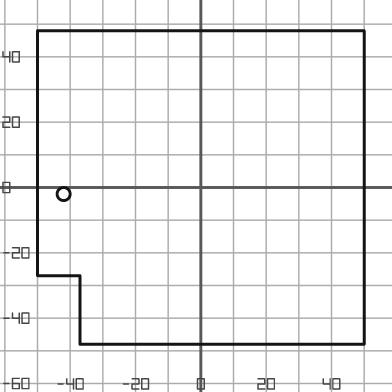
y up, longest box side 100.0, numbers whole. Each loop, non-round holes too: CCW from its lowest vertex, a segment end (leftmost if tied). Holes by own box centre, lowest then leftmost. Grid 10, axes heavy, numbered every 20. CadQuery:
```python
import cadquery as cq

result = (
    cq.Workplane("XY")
    .moveTo(-37.0, -48.0)
    .lineTo(50.0, -48.0)
    .lineTo(50.0, 48.0)
    .lineTo(-50.0, 48.0)
    .lineTo(-50.0, -27.0)
    .lineTo(-37.0, -27.0)
    .close()
    .moveTo(-42.0, -2.0)
    .circle(2.0)
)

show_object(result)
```